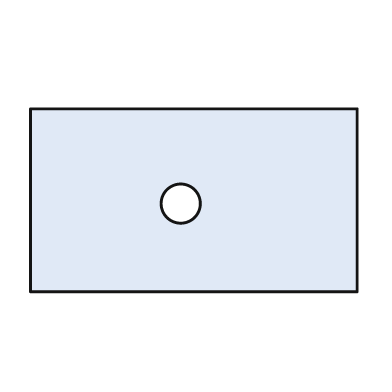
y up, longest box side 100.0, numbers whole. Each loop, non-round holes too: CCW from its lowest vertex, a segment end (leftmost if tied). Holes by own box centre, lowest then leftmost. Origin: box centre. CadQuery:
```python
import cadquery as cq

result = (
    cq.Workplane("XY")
    .moveTo(-50.0, -28.0)
    .lineTo(50.0, -28.0)
    .lineTo(50.0, 28.0)
    .lineTo(-50.0, 28.0)
    .close()
    .moveTo(-4.0, -1.0)
    .circle(6.0)
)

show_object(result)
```